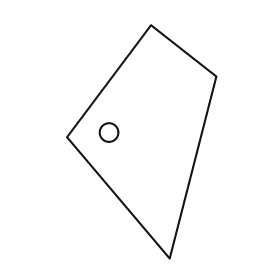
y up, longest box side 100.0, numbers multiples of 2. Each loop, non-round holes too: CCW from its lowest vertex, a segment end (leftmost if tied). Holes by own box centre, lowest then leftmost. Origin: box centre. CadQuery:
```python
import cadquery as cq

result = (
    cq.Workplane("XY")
    .moveTo(12.0, -50.0)
    .lineTo(32.0, 28.0)
    .lineTo(4.0, 50.0)
    .lineTo(-32.0, 2.0)
    .close()
    .moveTo(-14.0, 4.0)
    .circle(4.0)
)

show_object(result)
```